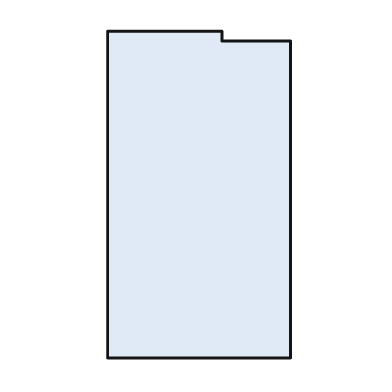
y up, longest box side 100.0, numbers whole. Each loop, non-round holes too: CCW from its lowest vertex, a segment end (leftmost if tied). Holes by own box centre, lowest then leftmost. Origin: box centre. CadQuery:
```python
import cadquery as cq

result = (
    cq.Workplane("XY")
    .moveTo(-28.0, -50.0)
    .lineTo(28.0, -50.0)
    .lineTo(28.0, 47.0)
    .lineTo(7.0, 47.0)
    .lineTo(7.0, 50.0)
    .lineTo(-28.0, 50.0)
    .close()
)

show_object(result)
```